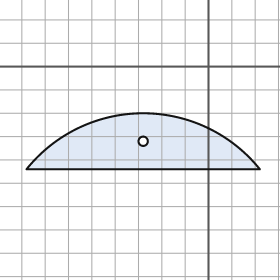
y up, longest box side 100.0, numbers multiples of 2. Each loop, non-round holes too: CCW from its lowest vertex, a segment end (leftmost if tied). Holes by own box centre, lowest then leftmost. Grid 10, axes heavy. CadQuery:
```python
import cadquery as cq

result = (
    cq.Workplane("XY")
    .moveTo(-78.0, -44.0)
    .lineTo(22.0, -44.0)
    .threePointArc((-28.0, -20.0), (-78.0, -44.0))
    .close()
    .moveTo(-28.0, -32.0)
    .circle(2.0)
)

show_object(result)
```